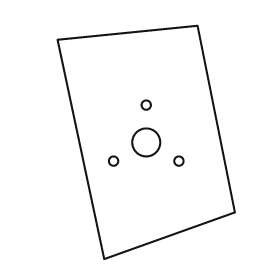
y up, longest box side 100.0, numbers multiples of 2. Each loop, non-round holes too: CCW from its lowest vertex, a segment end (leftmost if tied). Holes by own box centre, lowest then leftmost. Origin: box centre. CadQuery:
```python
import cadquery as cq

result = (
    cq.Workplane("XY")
    .moveTo(-18.0, -50.0)
    .lineTo(38.0, -30.0)
    .lineTo(22.0, 50.0)
    .lineTo(-38.0, 44.0)
    .close()
    .moveTo(-14.0, -8.0)
    .circle(2.0)
    .moveTo(14.0, -8.0)
    .circle(2.0)
    .moveTo(0.0, 0.0)
    .circle(6.0)
    .moveTo(0.0, 16.0)
    .circle(2.0)
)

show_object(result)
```